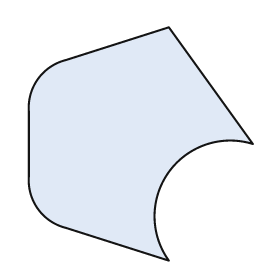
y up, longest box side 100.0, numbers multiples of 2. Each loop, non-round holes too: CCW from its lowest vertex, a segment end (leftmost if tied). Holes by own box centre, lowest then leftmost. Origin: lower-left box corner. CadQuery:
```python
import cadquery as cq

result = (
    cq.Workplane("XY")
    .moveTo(60.0, 0.0)
    .threePointArc((60.0, 38.0), (96.0, 50.0))
    .lineTo(60.0, 100.0)
    .lineTo(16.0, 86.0)
    .threePointArc((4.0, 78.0), (0.0, 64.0))
    .lineTo(0.0, 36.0)
    .threePointArc((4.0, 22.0), (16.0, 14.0))
    .close()
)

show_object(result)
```